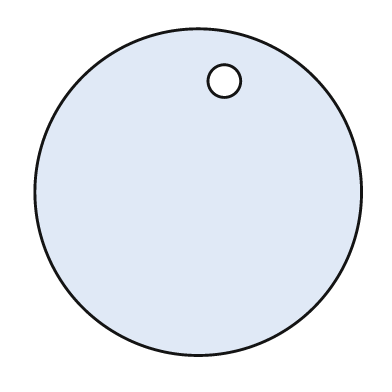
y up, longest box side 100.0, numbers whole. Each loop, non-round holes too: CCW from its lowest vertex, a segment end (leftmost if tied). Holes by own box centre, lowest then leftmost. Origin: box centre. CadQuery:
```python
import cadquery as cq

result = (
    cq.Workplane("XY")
    .moveTo(0.0, 0.0)
    .circle(50.0)
    .moveTo(8.0, 34.0)
    .circle(5.0)
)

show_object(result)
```